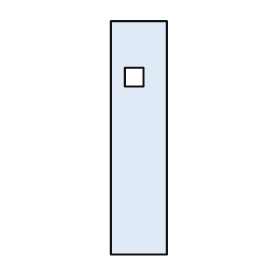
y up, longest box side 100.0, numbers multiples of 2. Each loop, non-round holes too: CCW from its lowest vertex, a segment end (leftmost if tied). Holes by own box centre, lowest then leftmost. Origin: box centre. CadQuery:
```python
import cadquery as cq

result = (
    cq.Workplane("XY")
    .moveTo(-12.0, -50.0)
    .lineTo(12.0, -50.0)
    .lineTo(12.0, 50.0)
    .lineTo(-12.0, 50.0)
    .close()
    .moveTo(-6.0, 22.0)
    .lineTo(2.0, 22.0)
    .lineTo(2.0, 30.0)
    .lineTo(-6.0, 30.0)
    .close()
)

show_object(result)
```